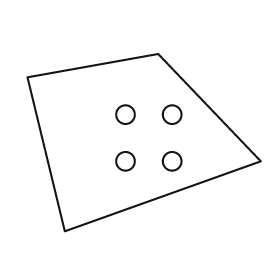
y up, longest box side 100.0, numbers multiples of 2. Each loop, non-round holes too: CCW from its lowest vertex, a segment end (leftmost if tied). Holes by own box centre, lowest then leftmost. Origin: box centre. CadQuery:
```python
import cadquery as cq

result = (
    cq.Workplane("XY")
    .moveTo(-34.0, -38.0)
    .lineTo(50.0, -8.0)
    .lineTo(6.0, 38.0)
    .lineTo(-50.0, 28.0)
    .close()
    .moveTo(-8.0, -8.0)
    .circle(4.0)
    .moveTo(12.0, -8.0)
    .circle(4.0)
    .moveTo(-8.0, 12.0)
    .circle(4.0)
    .moveTo(12.0, 12.0)
    .circle(4.0)
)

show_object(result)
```